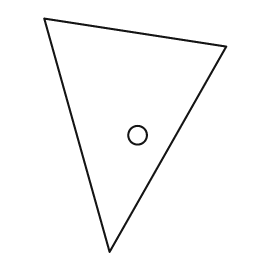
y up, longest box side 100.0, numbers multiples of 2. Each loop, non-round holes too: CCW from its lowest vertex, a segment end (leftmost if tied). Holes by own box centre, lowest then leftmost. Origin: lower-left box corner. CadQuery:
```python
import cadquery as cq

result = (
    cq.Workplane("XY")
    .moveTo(28.0, 0.0)
    .lineTo(78.0, 88.0)
    .lineTo(0.0, 100.0)
    .close()
    .moveTo(40.0, 50.0)
    .circle(4.0)
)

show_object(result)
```